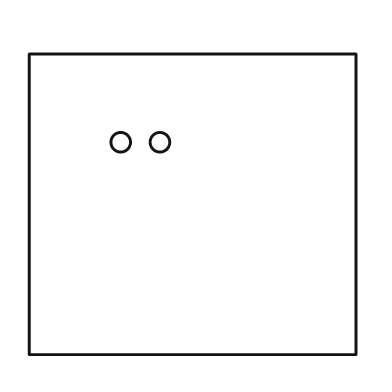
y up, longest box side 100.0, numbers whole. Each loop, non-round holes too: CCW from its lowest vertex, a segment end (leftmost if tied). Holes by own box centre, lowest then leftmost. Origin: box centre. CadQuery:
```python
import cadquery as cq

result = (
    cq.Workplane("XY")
    .moveTo(-50.0, -46.0)
    .lineTo(50.0, -46.0)
    .lineTo(50.0, 46.0)
    .lineTo(-50.0, 46.0)
    .close()
    .moveTo(-22.0, 19.0)
    .circle(3.0)
    .moveTo(-10.0, 19.0)
    .circle(3.0)
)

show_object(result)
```